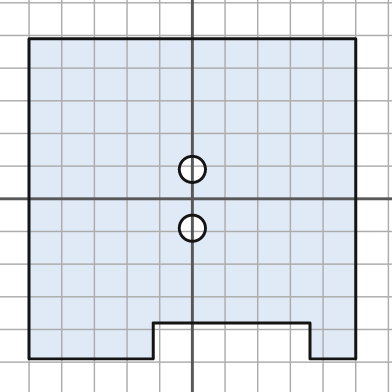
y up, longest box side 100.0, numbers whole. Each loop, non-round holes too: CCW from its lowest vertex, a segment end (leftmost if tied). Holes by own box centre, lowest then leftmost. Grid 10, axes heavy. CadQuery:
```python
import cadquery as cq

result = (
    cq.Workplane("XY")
    .moveTo(-50.0, -49.0)
    .lineTo(-12.0, -49.0)
    .lineTo(-12.0, -38.0)
    .lineTo(36.0, -38.0)
    .lineTo(36.0, -49.0)
    .lineTo(50.0, -49.0)
    .lineTo(50.0, 49.0)
    .lineTo(-50.0, 49.0)
    .close()
    .moveTo(0.0, -9.0)
    .circle(4.0)
    .moveTo(0.0, 9.0)
    .circle(4.0)
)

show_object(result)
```